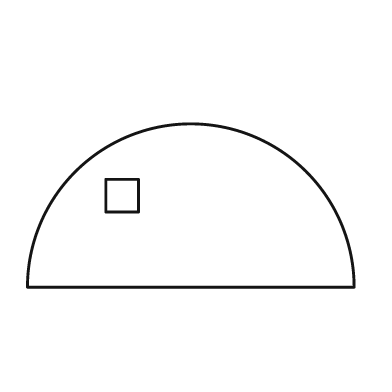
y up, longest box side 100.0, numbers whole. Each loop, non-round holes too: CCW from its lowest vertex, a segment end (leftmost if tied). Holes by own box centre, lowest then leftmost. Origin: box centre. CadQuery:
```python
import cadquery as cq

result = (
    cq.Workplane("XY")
    .moveTo(-50.0, -25.0)
    .lineTo(50.0, -25.0)
    .threePointArc((0.0, 25.0), (-50.0, -25.0))
    .close()
    .moveTo(-26.0, -2.0)
    .lineTo(-16.0, -2.0)
    .lineTo(-16.0, 8.0)
    .lineTo(-26.0, 8.0)
    .close()
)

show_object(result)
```